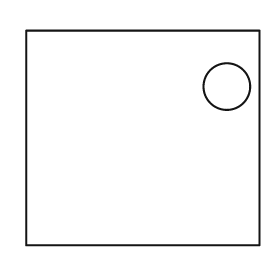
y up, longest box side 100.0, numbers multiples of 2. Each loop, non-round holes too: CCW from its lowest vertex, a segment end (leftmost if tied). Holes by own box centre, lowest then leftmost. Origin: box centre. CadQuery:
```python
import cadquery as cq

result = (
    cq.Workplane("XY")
    .moveTo(-50.0, -46.0)
    .lineTo(50.0, -46.0)
    .lineTo(50.0, 46.0)
    .lineTo(-50.0, 46.0)
    .close()
    .moveTo(36.0, 22.0)
    .circle(10.0)
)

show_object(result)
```